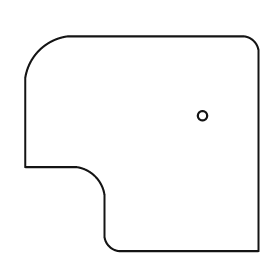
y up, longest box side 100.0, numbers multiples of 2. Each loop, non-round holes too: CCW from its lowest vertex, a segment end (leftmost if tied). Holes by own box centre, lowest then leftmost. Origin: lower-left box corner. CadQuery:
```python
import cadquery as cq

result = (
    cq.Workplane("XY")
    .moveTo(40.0, 0.0)
    .lineTo(100.0, 0.0)
    .lineTo(100.0, 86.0)
    .threePointArc((98.0, 90.0), (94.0, 92.0))
    .lineTo(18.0, 92.0)
    .threePointArc((6.0, 86.0), (0.0, 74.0))
    .lineTo(0.0, 36.0)
    .lineTo(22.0, 36.0)
    .threePointArc((30.0, 32.0), (34.0, 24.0))
    .lineTo(34.0, 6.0)
    .threePointArc((36.0, 2.0), (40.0, 0.0))
    .close()
    .moveTo(76.0, 58.0)
    .circle(2.0)
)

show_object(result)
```